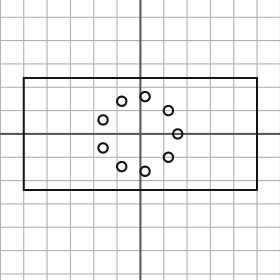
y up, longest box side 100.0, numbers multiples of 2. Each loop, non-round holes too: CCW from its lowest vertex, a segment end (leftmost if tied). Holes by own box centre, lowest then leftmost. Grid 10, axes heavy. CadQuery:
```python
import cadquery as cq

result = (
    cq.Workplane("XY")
    .moveTo(-50.0, -24.0)
    .lineTo(50.0, -24.0)
    .lineTo(50.0, 24.0)
    .lineTo(-50.0, 24.0)
    .close()
    .moveTo(2.0, -16.0)
    .circle(2.0)
    .moveTo(-8.0, -14.0)
    .circle(2.0)
    .moveTo(12.0, -10.0)
    .circle(2.0)
    .moveTo(-16.0, -6.0)
    .circle(2.0)
    .moveTo(16.0, 0.0)
    .circle(2.0)
    .moveTo(-16.0, 6.0)
    .circle(2.0)
    .moveTo(12.0, 10.0)
    .circle(2.0)
    .moveTo(-8.0, 14.0)
    .circle(2.0)
    .moveTo(2.0, 16.0)
    .circle(2.0)
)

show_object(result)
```